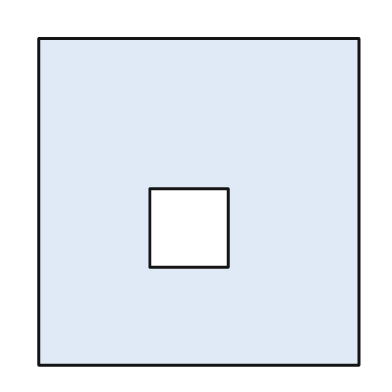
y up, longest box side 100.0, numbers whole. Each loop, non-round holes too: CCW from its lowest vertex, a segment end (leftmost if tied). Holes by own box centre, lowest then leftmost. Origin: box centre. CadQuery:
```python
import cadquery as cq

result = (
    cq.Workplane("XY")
    .moveTo(-49.0, -50.0)
    .lineTo(49.0, -50.0)
    .lineTo(49.0, 50.0)
    .lineTo(-49.0, 50.0)
    .close()
    .moveTo(-15.0, -20.0)
    .lineTo(9.0, -20.0)
    .lineTo(9.0, 4.0)
    .lineTo(-15.0, 4.0)
    .close()
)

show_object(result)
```